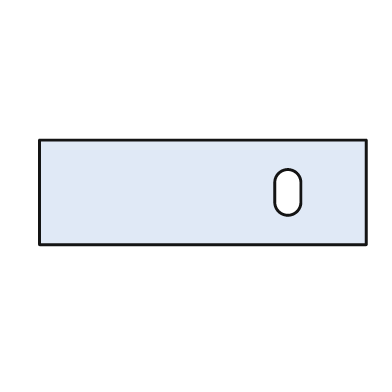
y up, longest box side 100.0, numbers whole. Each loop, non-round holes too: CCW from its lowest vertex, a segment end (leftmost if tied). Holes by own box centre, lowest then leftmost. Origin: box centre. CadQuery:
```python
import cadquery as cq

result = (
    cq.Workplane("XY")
    .moveTo(-50.0, -16.0)
    .lineTo(50.0, -16.0)
    .lineTo(50.0, 16.0)
    .lineTo(-50.0, 16.0)
    .close()
    .moveTo(22.0, -3.0)
    .threePointArc((26.0, -7.0), (30.0, -3.0))
    .lineTo(30.0, 3.0)
    .threePointArc((26.0, 7.0), (22.0, 3.0))
    .close()
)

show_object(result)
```